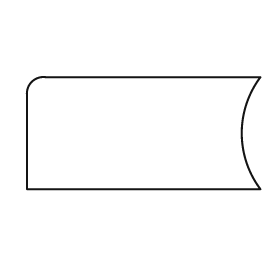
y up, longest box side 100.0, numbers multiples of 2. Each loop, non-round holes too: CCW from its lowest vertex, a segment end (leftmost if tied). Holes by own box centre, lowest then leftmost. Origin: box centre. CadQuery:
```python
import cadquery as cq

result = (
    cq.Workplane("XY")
    .moveTo(-50.0, -24.0)
    .lineTo(50.0, -24.0)
    .threePointArc((42.0, 0.0), (50.0, 24.0))
    .lineTo(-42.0, 24.0)
    .threePointArc((-48.0, 22.0), (-50.0, 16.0))
    .close()
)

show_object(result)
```